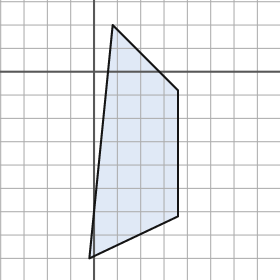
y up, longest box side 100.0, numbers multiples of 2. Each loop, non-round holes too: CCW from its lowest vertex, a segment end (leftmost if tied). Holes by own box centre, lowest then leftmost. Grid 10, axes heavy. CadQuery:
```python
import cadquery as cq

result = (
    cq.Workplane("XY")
    .moveTo(-2.0, -80.0)
    .lineTo(36.0, -62.0)
    .lineTo(36.0, -8.0)
    .lineTo(8.0, 20.0)
    .close()
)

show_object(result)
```